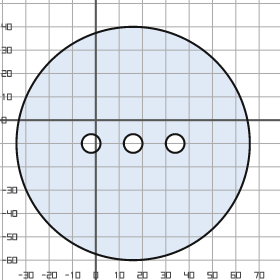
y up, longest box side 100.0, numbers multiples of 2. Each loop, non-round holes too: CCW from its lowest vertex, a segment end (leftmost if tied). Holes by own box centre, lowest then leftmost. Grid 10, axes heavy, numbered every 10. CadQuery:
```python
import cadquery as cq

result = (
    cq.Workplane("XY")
    .moveTo(16.0, -10.0)
    .circle(50.0)
    .moveTo(-2.0, -10.0)
    .circle(4.0)
    .moveTo(16.0, -10.0)
    .circle(4.0)
    .moveTo(34.0, -10.0)
    .circle(4.0)
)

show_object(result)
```